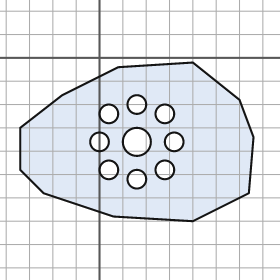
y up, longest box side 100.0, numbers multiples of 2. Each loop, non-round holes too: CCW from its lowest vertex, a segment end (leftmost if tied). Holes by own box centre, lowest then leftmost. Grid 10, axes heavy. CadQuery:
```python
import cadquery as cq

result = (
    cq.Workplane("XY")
    .moveTo(40.0, -70.0)
    .lineTo(64.0, -58.0)
    .lineTo(66.0, -34.0)
    .lineTo(60.0, -18.0)
    .lineTo(40.0, -2.0)
    .lineTo(8.0, -4.0)
    .lineTo(-16.0, -16.0)
    .lineTo(-34.0, -30.0)
    .lineTo(-34.0, -48.0)
    .lineTo(-24.0, -58.0)
    .lineTo(6.0, -68.0)
    .close()
    .moveTo(16.0, -52.0)
    .circle(4.0)
    .moveTo(4.0, -48.0)
    .circle(4.0)
    .moveTo(28.0, -48.0)
    .circle(4.0)
    .moveTo(0.0, -36.0)
    .circle(4.0)
    .moveTo(16.0, -36.0)
    .circle(6.0)
    .moveTo(32.0, -36.0)
    .circle(4.0)
    .moveTo(4.0, -24.0)
    .circle(4.0)
    .moveTo(28.0, -24.0)
    .circle(4.0)
    .moveTo(16.0, -20.0)
    .circle(4.0)
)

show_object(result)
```